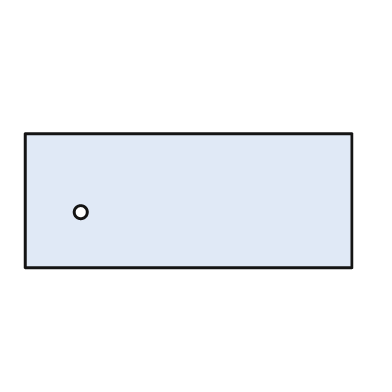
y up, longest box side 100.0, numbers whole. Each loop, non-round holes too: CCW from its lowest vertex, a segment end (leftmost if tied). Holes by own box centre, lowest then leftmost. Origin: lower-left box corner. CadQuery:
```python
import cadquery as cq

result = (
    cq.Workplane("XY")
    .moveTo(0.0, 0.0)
    .lineTo(100.0, 0.0)
    .lineTo(100.0, 41.0)
    .lineTo(0.0, 41.0)
    .close()
    .moveTo(17.0, 17.0)
    .circle(2.0)
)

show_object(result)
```